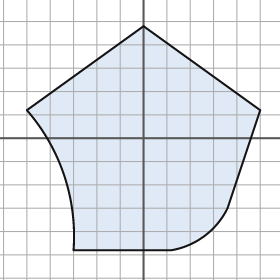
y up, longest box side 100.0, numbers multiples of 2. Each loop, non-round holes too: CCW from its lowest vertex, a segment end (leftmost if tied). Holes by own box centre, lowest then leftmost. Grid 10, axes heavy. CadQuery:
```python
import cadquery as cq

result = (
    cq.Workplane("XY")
    .moveTo(-30.0, -48.0)
    .lineTo(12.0, -48.0)
    .threePointArc((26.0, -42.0), (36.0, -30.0))
    .lineTo(50.0, 12.0)
    .lineTo(0.0, 48.0)
    .lineTo(-50.0, 12.0)
    .threePointArc((-34.0, -16.0), (-30.0, -48.0))
    .close()
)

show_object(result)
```